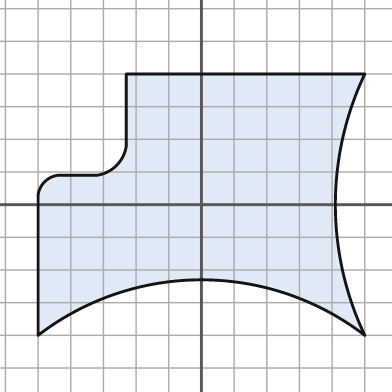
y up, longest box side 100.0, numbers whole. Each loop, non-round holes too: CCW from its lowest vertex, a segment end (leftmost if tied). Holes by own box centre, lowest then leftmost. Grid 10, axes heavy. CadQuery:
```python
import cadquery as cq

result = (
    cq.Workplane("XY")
    .moveTo(-50.0, -40.0)
    .threePointArc((0.0, -23.0), (50.0, -40.0))
    .threePointArc((41.0, 0.0), (50.0, 40.0))
    .lineTo(-23.0, 40.0)
    .lineTo(-23.0, 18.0)
    .threePointArc((-26.0, 12.0), (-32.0, 9.0))
    .lineTo(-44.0, 9.0)
    .threePointArc((-48.0, 7.0), (-50.0, 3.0))
    .close()
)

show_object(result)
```